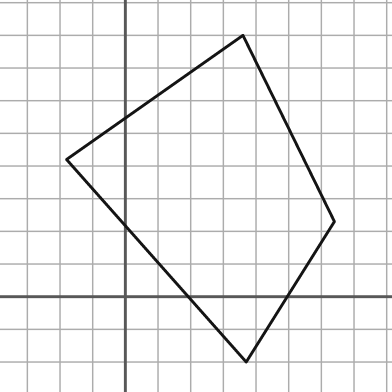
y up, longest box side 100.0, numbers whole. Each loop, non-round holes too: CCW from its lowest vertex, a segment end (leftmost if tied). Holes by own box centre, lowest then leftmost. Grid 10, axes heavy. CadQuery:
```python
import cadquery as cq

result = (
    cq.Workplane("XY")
    .moveTo(37.0, -20.0)
    .lineTo(64.0, 23.0)
    .lineTo(36.0, 80.0)
    .lineTo(-18.0, 42.0)
    .close()
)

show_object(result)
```